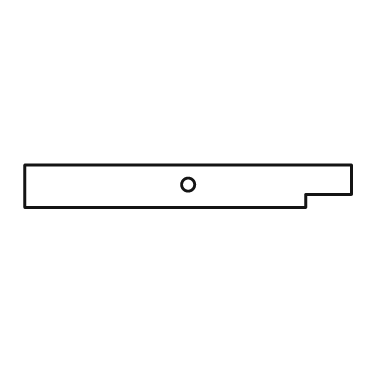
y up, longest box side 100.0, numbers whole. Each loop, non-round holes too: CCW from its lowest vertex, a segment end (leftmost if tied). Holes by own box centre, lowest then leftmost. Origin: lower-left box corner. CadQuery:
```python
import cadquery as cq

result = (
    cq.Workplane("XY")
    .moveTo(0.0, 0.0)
    .lineTo(86.0, 0.0)
    .lineTo(86.0, 4.0)
    .lineTo(100.0, 4.0)
    .lineTo(100.0, 13.0)
    .lineTo(0.0, 13.0)
    .close()
    .moveTo(50.0, 7.0)
    .circle(2.0)
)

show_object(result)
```